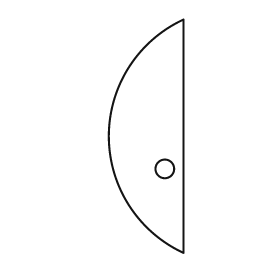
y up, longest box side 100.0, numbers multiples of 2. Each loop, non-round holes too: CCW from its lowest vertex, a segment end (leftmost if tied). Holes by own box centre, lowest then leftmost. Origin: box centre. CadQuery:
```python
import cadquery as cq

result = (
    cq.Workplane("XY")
    .moveTo(16.0, -50.0)
    .lineTo(16.0, 50.0)
    .threePointArc((-16.0, 0.0), (16.0, -50.0))
    .close()
    .moveTo(8.0, -14.0)
    .circle(4.0)
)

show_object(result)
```